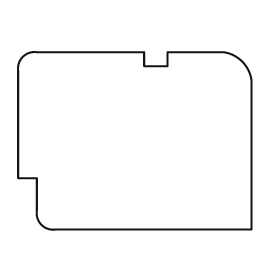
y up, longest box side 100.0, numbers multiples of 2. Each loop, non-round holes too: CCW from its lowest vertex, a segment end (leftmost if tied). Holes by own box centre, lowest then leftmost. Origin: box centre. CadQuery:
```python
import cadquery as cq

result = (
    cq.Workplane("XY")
    .moveTo(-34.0, -38.0)
    .lineTo(50.0, -38.0)
    .lineTo(50.0, 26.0)
    .threePointArc((46.0, 34.0), (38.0, 38.0))
    .lineTo(14.0, 38.0)
    .lineTo(14.0, 32.0)
    .lineTo(4.0, 32.0)
    .lineTo(4.0, 38.0)
    .lineTo(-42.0, 38.0)
    .threePointArc((-48.0, 36.0), (-50.0, 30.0))
    .lineTo(-50.0, -16.0)
    .lineTo(-42.0, -16.0)
    .lineTo(-42.0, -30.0)
    .threePointArc((-40.0, -36.0), (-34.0, -38.0))
    .close()
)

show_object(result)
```